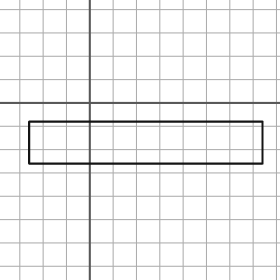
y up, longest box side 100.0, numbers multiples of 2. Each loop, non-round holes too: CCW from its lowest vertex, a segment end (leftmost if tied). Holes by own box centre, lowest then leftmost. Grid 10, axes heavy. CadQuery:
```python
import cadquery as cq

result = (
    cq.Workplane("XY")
    .moveTo(-26.0, -26.0)
    .lineTo(74.0, -26.0)
    .lineTo(74.0, -8.0)
    .lineTo(-26.0, -8.0)
    .close()
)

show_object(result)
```